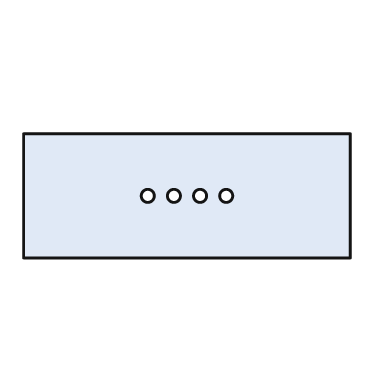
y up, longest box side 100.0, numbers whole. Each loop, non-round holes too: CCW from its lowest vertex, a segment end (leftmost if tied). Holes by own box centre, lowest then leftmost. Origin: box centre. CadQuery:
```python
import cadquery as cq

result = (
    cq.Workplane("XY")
    .moveTo(-50.0, -19.0)
    .lineTo(50.0, -19.0)
    .lineTo(50.0, 19.0)
    .lineTo(-50.0, 19.0)
    .close()
    .moveTo(-12.0, 0.0)
    .circle(2.0)
    .moveTo(-4.0, 0.0)
    .circle(2.0)
    .moveTo(4.0, 0.0)
    .circle(2.0)
    .moveTo(12.0, 0.0)
    .circle(2.0)
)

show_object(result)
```